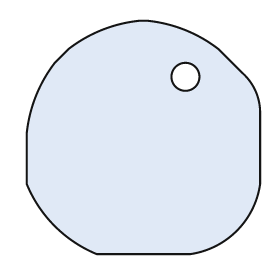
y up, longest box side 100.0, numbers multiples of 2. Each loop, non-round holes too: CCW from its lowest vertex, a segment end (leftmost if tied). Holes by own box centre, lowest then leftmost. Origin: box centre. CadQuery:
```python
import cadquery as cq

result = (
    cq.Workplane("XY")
    .moveTo(-20.0, -50.0)
    .lineTo(20.0, -50.0)
    .threePointArc((40.0, -40.0), (50.0, -20.0))
    .lineTo(50.0, 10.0)
    .threePointArc((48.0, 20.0), (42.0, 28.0))
    .lineTo(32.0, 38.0)
    .threePointArc((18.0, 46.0), (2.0, 50.0))
    .lineTo(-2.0, 50.0)
    .threePointArc((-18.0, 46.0), (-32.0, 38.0))
    .lineTo(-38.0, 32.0)
    .threePointArc((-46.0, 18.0), (-50.0, 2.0))
    .lineTo(-50.0, -20.0)
    .threePointArc((-38.0, -38.0), (-20.0, -50.0))
    .close()
    .moveTo(18.0, 26.0)
    .circle(6.0)
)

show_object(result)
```